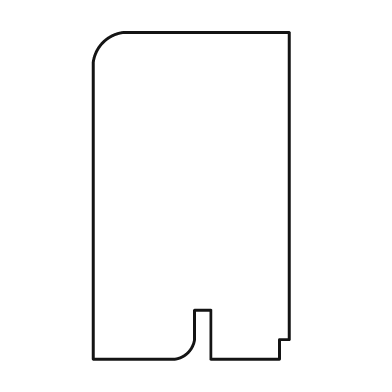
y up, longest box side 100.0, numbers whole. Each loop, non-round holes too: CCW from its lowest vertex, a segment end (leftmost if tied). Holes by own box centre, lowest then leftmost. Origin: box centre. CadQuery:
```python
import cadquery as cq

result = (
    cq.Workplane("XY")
    .moveTo(-30.0, -50.0)
    .lineTo(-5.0, -50.0)
    .threePointArc((-1.0, -48.0), (1.0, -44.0))
    .lineTo(1.0, -35.0)
    .lineTo(6.0, -35.0)
    .lineTo(6.0, -50.0)
    .lineTo(27.0, -50.0)
    .lineTo(27.0, -44.0)
    .lineTo(30.0, -44.0)
    .lineTo(30.0, 50.0)
    .lineTo(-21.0, 50.0)
    .threePointArc((-27.0, 47.0), (-30.0, 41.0))
    .close()
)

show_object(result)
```